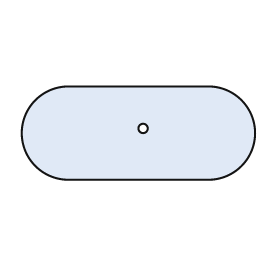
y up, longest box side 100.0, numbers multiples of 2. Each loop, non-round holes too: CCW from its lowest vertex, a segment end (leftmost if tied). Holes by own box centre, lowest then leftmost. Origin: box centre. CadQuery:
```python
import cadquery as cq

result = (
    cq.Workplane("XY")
    .moveTo(-30.0, -20.0)
    .lineTo(30.0, -20.0)
    .threePointArc((50.0, 0.0), (30.0, 20.0))
    .lineTo(-30.0, 20.0)
    .threePointArc((-50.0, 0.0), (-30.0, -20.0))
    .close()
    .moveTo(2.0, 2.0)
    .circle(2.0)
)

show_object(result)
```